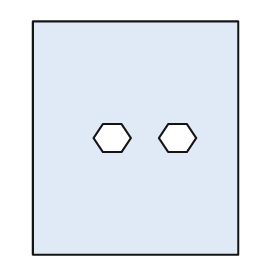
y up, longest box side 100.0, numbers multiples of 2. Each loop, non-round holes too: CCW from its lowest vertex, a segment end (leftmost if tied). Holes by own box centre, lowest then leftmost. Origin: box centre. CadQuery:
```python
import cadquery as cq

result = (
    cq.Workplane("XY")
    .moveTo(-44.0, -50.0)
    .lineTo(44.0, -50.0)
    .lineTo(44.0, 50.0)
    .lineTo(-44.0, 50.0)
    .close()
    .moveTo(-14.0, -6.0)
    .lineTo(-6.0, -6.0)
    .lineTo(-2.0, 0.0)
    .lineTo(-6.0, 6.0)
    .lineTo(-14.0, 6.0)
    .lineTo(-18.0, 0.0)
    .close()
    .moveTo(14.0, -6.0)
    .lineTo(22.0, -6.0)
    .lineTo(26.0, 0.0)
    .lineTo(22.0, 6.0)
    .lineTo(14.0, 6.0)
    .lineTo(10.0, 0.0)
    .close()
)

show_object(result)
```